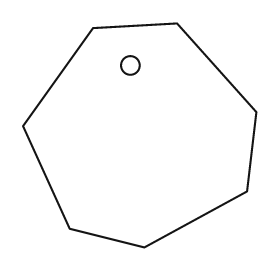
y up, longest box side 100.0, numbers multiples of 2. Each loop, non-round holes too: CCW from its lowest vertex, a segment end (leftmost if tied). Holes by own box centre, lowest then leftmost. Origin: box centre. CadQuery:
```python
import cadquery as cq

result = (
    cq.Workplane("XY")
    .moveTo(2.0, -48.0)
    .lineTo(46.0, -24.0)
    .lineTo(50.0, 10.0)
    .lineTo(16.0, 48.0)
    .lineTo(-20.0, 46.0)
    .lineTo(-50.0, 4.0)
    .lineTo(-30.0, -40.0)
    .close()
    .moveTo(-4.0, 30.0)
    .circle(4.0)
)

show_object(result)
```